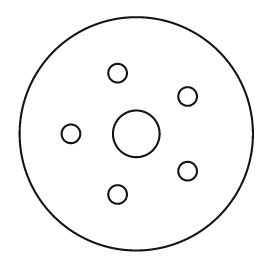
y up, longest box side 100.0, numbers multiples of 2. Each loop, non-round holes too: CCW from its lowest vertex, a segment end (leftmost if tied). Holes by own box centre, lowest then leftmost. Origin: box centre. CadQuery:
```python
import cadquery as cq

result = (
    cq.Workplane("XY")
    .moveTo(0.0, 0.0)
    .circle(50.0)
    .moveTo(-8.0, -26.0)
    .circle(4.0)
    .moveTo(22.0, -16.0)
    .circle(4.0)
    .moveTo(-28.0, 0.0)
    .circle(4.0)
    .moveTo(0.0, 0.0)
    .circle(10.0)
    .moveTo(22.0, 16.0)
    .circle(4.0)
    .moveTo(-8.0, 26.0)
    .circle(4.0)
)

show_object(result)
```